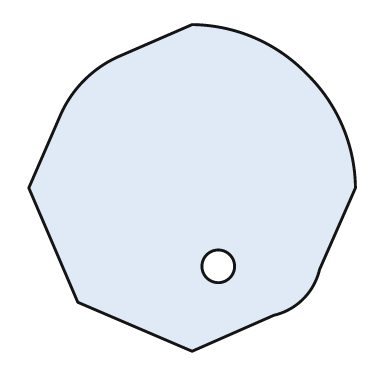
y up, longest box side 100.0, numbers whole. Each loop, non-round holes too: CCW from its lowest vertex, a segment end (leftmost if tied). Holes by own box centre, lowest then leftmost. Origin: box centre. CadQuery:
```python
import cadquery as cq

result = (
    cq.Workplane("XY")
    .moveTo(0.0, -50.0)
    .lineTo(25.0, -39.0)
    .threePointArc((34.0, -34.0), (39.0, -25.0))
    .lineTo(50.0, 0.0)
    .threePointArc((46.0, 19.0), (35.0, 35.0))
    .threePointArc((19.0, 46.0), (0.0, 50.0))
    .lineTo(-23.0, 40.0)
    .threePointArc((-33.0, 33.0), (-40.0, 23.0))
    .lineTo(-50.0, 0.0)
    .lineTo(-35.0, -35.0)
    .close()
    .moveTo(8.0, -24.0)
    .circle(5.0)
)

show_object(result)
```